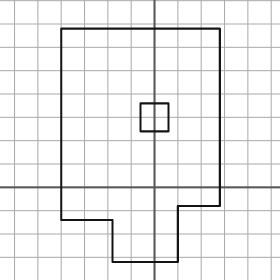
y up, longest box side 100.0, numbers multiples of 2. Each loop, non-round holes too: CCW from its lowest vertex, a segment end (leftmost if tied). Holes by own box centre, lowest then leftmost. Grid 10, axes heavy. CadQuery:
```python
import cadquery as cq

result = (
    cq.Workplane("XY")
    .moveTo(-18.0, -32.0)
    .lineTo(10.0, -32.0)
    .lineTo(10.0, -8.0)
    .lineTo(28.0, -8.0)
    .lineTo(28.0, 68.0)
    .lineTo(-40.0, 68.0)
    .lineTo(-40.0, -14.0)
    .lineTo(-18.0, -14.0)
    .close()
    .moveTo(-6.0, 24.0)
    .lineTo(6.0, 24.0)
    .lineTo(6.0, 36.0)
    .lineTo(-6.0, 36.0)
    .close()
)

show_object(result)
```